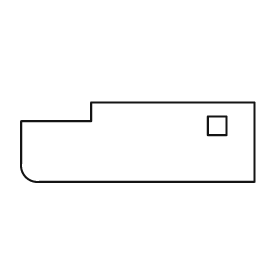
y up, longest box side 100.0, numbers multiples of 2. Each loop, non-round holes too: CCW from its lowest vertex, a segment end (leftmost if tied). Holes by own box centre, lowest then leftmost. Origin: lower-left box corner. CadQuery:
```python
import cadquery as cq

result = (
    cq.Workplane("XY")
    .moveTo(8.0, 0.0)
    .lineTo(100.0, 0.0)
    .lineTo(100.0, 34.0)
    .lineTo(30.0, 34.0)
    .lineTo(30.0, 26.0)
    .lineTo(0.0, 26.0)
    .lineTo(0.0, 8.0)
    .threePointArc((2.0, 2.0), (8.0, 0.0))
    .close()
    .moveTo(80.0, 20.0)
    .lineTo(88.0, 20.0)
    .lineTo(88.0, 28.0)
    .lineTo(80.0, 28.0)
    .close()
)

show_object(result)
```